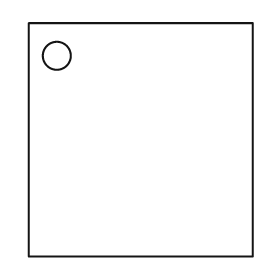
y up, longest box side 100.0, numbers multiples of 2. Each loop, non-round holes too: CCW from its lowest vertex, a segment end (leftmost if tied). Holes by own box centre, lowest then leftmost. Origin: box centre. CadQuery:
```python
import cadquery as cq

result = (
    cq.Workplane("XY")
    .moveTo(-48.0, -50.0)
    .lineTo(48.0, -50.0)
    .lineTo(48.0, 50.0)
    .lineTo(-48.0, 50.0)
    .close()
    .moveTo(-36.0, 36.0)
    .circle(6.0)
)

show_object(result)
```